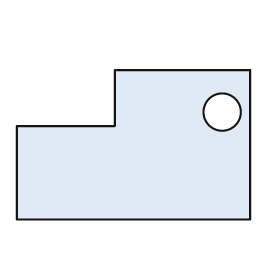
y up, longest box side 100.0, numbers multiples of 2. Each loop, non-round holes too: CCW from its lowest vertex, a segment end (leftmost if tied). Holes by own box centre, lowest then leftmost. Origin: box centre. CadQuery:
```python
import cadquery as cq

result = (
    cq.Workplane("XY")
    .moveTo(-50.0, -32.0)
    .lineTo(50.0, -32.0)
    .lineTo(50.0, 32.0)
    .lineTo(-8.0, 32.0)
    .lineTo(-8.0, 8.0)
    .lineTo(-50.0, 8.0)
    .close()
    .moveTo(38.0, 14.0)
    .circle(8.0)
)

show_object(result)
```